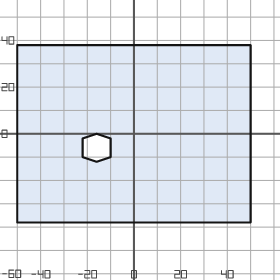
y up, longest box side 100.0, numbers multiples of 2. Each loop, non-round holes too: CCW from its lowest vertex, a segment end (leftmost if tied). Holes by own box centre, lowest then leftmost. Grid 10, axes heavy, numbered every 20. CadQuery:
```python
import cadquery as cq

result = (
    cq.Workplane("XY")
    .moveTo(-50.0, -38.0)
    .lineTo(50.0, -38.0)
    .lineTo(50.0, 38.0)
    .lineTo(-50.0, 38.0)
    .close()
    .moveTo(-16.0, -12.0)
    .lineTo(-10.0, -10.0)
    .lineTo(-10.0, -2.0)
    .lineTo(-16.0, 0.0)
    .lineTo(-22.0, -2.0)
    .lineTo(-22.0, -10.0)
    .close()
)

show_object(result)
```